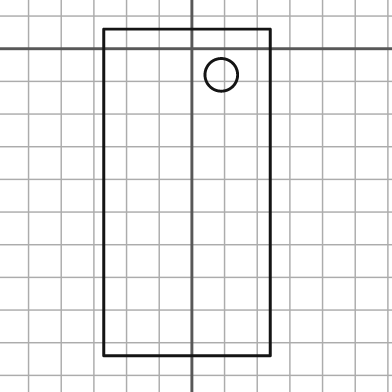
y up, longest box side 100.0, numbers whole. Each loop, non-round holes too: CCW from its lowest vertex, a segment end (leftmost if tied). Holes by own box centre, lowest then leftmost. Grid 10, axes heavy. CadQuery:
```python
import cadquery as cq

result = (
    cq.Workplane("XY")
    .moveTo(-27.0, -94.0)
    .lineTo(24.0, -94.0)
    .lineTo(24.0, 6.0)
    .lineTo(-27.0, 6.0)
    .close()
    .moveTo(9.0, -8.0)
    .circle(5.0)
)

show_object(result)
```